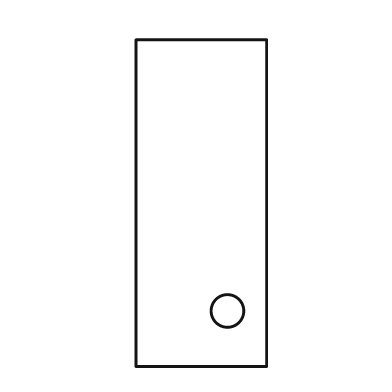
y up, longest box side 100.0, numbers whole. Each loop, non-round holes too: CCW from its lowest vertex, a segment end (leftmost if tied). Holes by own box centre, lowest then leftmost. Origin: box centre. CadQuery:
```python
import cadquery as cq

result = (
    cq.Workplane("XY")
    .moveTo(-20.0, -50.0)
    .lineTo(20.0, -50.0)
    .lineTo(20.0, 50.0)
    .lineTo(-20.0, 50.0)
    .close()
    .moveTo(8.0, -33.0)
    .circle(5.0)
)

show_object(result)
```